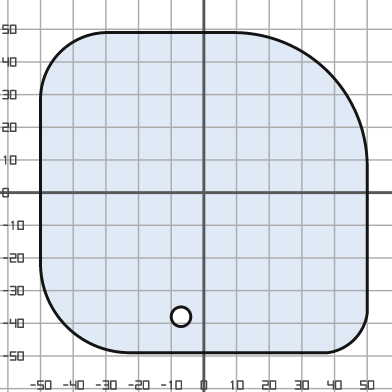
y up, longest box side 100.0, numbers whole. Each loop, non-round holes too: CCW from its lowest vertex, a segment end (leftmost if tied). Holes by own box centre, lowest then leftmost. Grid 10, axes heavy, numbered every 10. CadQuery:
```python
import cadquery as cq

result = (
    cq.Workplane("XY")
    .moveTo(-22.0, -49.0)
    .lineTo(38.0, -49.0)
    .threePointArc((46.0, -45.0), (50.0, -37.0))
    .lineTo(50.0, 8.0)
    .threePointArc((38.0, 37.0), (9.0, 49.0))
    .lineTo(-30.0, 49.0)
    .threePointArc((-44.0, 43.0), (-50.0, 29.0))
    .lineTo(-50.0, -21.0)
    .threePointArc((-42.0, -41.0), (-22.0, -49.0))
    .close()
    .moveTo(-7.0, -38.0)
    .circle(3.0)
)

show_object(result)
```